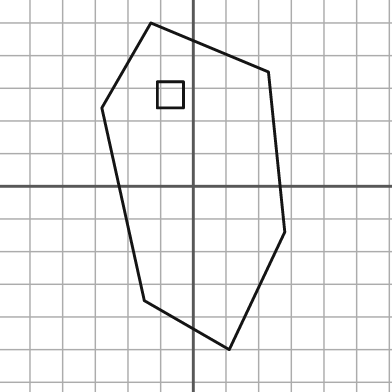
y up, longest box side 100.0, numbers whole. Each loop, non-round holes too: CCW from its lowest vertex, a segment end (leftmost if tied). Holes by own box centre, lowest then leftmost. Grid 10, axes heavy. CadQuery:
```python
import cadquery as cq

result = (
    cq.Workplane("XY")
    .moveTo(11.0, -50.0)
    .lineTo(28.0, -14.0)
    .lineTo(23.0, 35.0)
    .lineTo(-13.0, 50.0)
    .lineTo(-28.0, 24.0)
    .lineTo(-15.0, -35.0)
    .close()
    .moveTo(-11.0, 24.0)
    .lineTo(-3.0, 24.0)
    .lineTo(-3.0, 32.0)
    .lineTo(-11.0, 32.0)
    .close()
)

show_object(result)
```